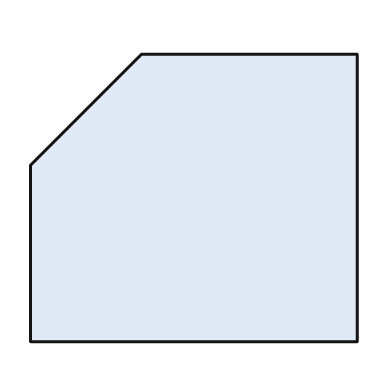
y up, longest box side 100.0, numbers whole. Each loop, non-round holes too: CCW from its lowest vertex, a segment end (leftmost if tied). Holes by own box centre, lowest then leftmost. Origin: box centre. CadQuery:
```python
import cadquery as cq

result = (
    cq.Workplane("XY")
    .moveTo(-50.0, -44.0)
    .lineTo(50.0, -44.0)
    .lineTo(50.0, 44.0)
    .lineTo(-16.0, 44.0)
    .lineTo(-50.0, 10.0)
    .close()
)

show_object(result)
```